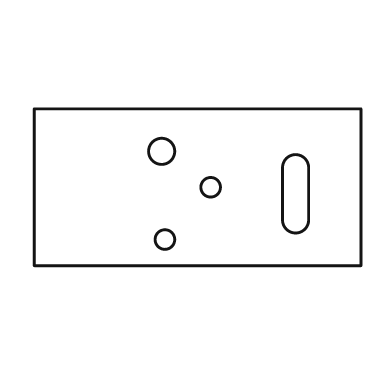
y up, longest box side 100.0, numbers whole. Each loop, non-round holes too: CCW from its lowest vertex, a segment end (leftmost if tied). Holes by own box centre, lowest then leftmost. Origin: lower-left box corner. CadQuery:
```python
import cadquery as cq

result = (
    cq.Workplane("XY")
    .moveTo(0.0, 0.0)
    .lineTo(100.0, 0.0)
    .lineTo(100.0, 48.0)
    .lineTo(0.0, 48.0)
    .close()
    .moveTo(40.0, 8.0)
    .circle(3.0)
    .moveTo(76.0, 14.0)
    .threePointArc((80.0, 10.0), (84.0, 14.0))
    .lineTo(84.0, 30.0)
    .threePointArc((80.0, 34.0), (76.0, 30.0))
    .close()
    .moveTo(54.0, 24.0)
    .circle(3.0)
    .moveTo(39.0, 35.0)
    .circle(4.0)
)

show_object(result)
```